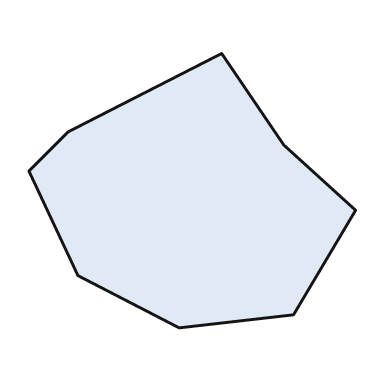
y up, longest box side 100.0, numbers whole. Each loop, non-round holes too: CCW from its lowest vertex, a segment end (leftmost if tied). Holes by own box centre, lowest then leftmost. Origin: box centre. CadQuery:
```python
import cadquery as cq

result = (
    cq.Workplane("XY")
    .moveTo(-4.0, -42.0)
    .lineTo(31.0, -38.0)
    .lineTo(50.0, -6.0)
    .lineTo(28.0, 14.0)
    .lineTo(9.0, 42.0)
    .lineTo(-38.0, 18.0)
    .lineTo(-50.0, 6.0)
    .lineTo(-35.0, -26.0)
    .close()
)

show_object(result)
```